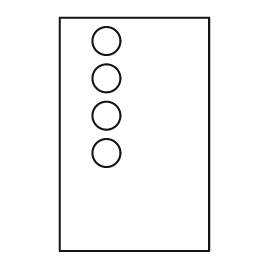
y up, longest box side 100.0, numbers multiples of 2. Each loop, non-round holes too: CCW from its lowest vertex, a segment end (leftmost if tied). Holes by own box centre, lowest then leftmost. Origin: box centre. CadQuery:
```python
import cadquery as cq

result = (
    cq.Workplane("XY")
    .moveTo(-32.0, -50.0)
    .lineTo(32.0, -50.0)
    .lineTo(32.0, 50.0)
    .lineTo(-32.0, 50.0)
    .close()
    .moveTo(-12.0, -8.0)
    .circle(6.0)
    .moveTo(-12.0, 8.0)
    .circle(6.0)
    .moveTo(-12.0, 24.0)
    .circle(6.0)
    .moveTo(-12.0, 40.0)
    .circle(6.0)
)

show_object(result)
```